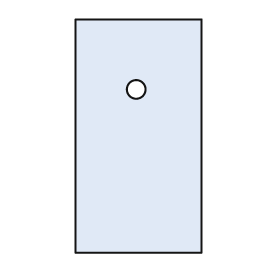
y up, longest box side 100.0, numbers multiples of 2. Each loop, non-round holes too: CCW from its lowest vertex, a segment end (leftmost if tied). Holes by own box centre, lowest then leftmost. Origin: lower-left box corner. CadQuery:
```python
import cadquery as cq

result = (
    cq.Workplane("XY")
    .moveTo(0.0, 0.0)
    .lineTo(54.0, 0.0)
    .lineTo(54.0, 100.0)
    .lineTo(0.0, 100.0)
    .close()
    .moveTo(26.0, 70.0)
    .circle(4.0)
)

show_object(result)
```